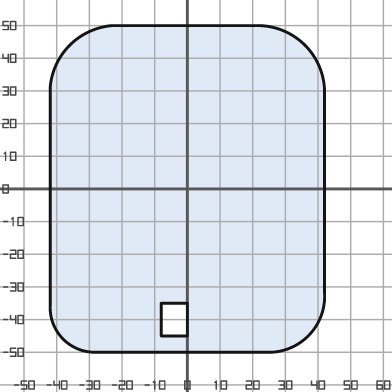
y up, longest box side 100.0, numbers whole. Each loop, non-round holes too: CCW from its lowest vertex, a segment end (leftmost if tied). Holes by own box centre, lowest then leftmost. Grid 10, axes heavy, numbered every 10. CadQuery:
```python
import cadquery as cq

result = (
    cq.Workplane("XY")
    .moveTo(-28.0, -50.0)
    .lineTo(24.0, -50.0)
    .threePointArc((37.0, -45.0), (42.0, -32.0))
    .lineTo(42.0, 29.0)
    .threePointArc((36.0, 44.0), (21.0, 50.0))
    .lineTo(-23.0, 50.0)
    .threePointArc((-36.0, 44.0), (-42.0, 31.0))
    .lineTo(-42.0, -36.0)
    .threePointArc((-38.0, -46.0), (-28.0, -50.0))
    .close()
    .moveTo(-8.0, -45.0)
    .lineTo(0.0, -45.0)
    .lineTo(0.0, -35.0)
    .lineTo(-8.0, -35.0)
    .close()
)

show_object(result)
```